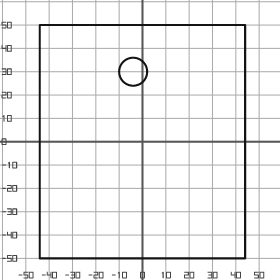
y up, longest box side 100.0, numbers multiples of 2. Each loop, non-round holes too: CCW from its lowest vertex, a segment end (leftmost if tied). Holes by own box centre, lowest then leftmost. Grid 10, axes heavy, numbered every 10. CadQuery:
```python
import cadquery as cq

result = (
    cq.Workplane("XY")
    .moveTo(-44.0, -50.0)
    .lineTo(44.0, -50.0)
    .lineTo(44.0, 50.0)
    .lineTo(-44.0, 50.0)
    .close()
    .moveTo(-4.0, 30.0)
    .circle(6.0)
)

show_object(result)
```